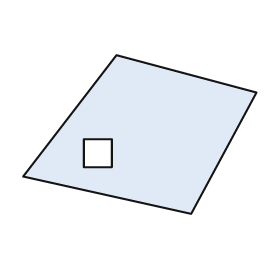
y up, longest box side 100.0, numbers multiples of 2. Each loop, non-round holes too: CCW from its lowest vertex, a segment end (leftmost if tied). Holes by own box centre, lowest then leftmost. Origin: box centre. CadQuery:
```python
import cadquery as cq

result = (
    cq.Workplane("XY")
    .moveTo(22.0, -34.0)
    .lineTo(50.0, 18.0)
    .lineTo(-10.0, 34.0)
    .lineTo(-50.0, -18.0)
    .close()
    .moveTo(-24.0, -14.0)
    .lineTo(-12.0, -14.0)
    .lineTo(-12.0, -2.0)
    .lineTo(-24.0, -2.0)
    .close()
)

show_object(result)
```